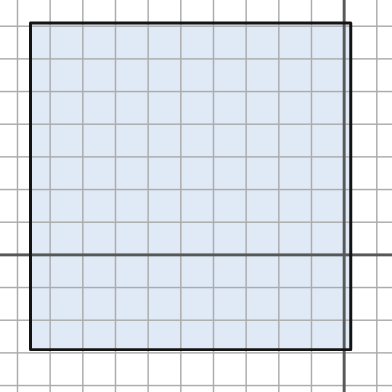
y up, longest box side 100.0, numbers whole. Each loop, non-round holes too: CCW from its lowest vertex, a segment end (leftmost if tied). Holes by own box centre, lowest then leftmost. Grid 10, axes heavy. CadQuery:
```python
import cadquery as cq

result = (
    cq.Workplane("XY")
    .moveTo(-96.0, -29.0)
    .lineTo(2.0, -29.0)
    .lineTo(2.0, 71.0)
    .lineTo(-96.0, 71.0)
    .close()
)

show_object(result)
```